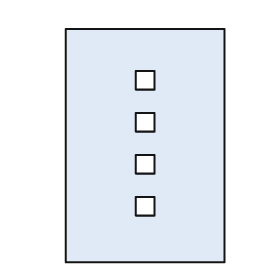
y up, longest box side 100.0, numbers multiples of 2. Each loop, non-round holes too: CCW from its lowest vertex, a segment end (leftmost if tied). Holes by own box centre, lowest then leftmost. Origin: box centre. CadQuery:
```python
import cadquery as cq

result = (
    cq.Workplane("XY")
    .moveTo(-34.0, -50.0)
    .lineTo(34.0, -50.0)
    .lineTo(34.0, 50.0)
    .lineTo(-34.0, 50.0)
    .close()
    .moveTo(-4.0, -30.0)
    .lineTo(4.0, -30.0)
    .lineTo(4.0, -22.0)
    .lineTo(-4.0, -22.0)
    .close()
    .moveTo(-4.0, -12.0)
    .lineTo(4.0, -12.0)
    .lineTo(4.0, -4.0)
    .lineTo(-4.0, -4.0)
    .close()
    .moveTo(-4.0, 6.0)
    .lineTo(4.0, 6.0)
    .lineTo(4.0, 14.0)
    .lineTo(-4.0, 14.0)
    .close()
    .moveTo(-4.0, 24.0)
    .lineTo(4.0, 24.0)
    .lineTo(4.0, 32.0)
    .lineTo(-4.0, 32.0)
    .close()
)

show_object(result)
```